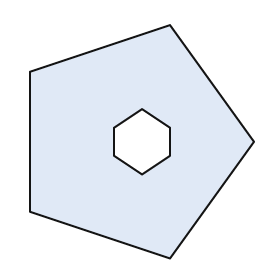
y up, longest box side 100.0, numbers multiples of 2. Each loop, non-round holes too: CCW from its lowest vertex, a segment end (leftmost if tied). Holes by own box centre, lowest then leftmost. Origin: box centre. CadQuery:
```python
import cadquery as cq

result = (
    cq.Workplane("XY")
    .moveTo(12.0, -50.0)
    .lineTo(48.0, 0.0)
    .lineTo(12.0, 50.0)
    .lineTo(-48.0, 30.0)
    .lineTo(-48.0, -30.0)
    .close()
    .moveTo(0.0, -14.0)
    .lineTo(12.0, -6.0)
    .lineTo(12.0, 6.0)
    .lineTo(0.0, 14.0)
    .lineTo(-12.0, 6.0)
    .lineTo(-12.0, -6.0)
    .close()
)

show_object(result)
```